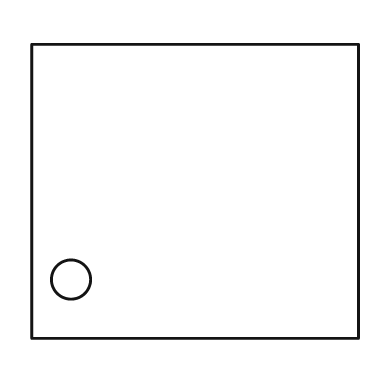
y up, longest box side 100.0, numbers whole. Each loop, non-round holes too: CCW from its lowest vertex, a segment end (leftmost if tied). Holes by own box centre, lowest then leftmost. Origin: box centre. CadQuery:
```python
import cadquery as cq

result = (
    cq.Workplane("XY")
    .moveTo(-50.0, -45.0)
    .lineTo(50.0, -45.0)
    .lineTo(50.0, 45.0)
    .lineTo(-50.0, 45.0)
    .close()
    .moveTo(-38.0, -27.0)
    .circle(6.0)
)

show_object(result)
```